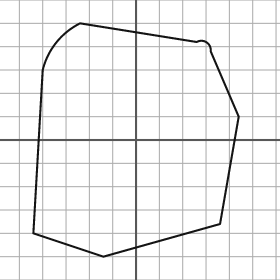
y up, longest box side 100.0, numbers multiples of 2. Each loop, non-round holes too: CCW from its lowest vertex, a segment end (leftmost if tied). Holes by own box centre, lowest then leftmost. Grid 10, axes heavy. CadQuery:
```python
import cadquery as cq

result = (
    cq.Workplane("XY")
    .moveTo(-14.0, -50.0)
    .lineTo(36.0, -36.0)
    .lineTo(44.0, 10.0)
    .lineTo(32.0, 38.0)
    .threePointArc((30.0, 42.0), (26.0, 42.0))
    .lineTo(-24.0, 50.0)
    .threePointArc((-34.0, 42.0), (-40.0, 30.0))
    .lineTo(-44.0, -40.0)
    .close()
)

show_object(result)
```